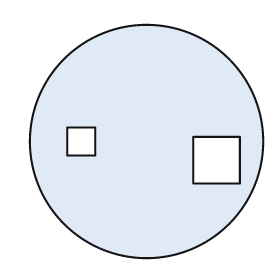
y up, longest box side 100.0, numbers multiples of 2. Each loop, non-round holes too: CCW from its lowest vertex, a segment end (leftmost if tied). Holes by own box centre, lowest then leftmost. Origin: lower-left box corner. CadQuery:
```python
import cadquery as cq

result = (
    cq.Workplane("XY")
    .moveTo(50.0, 50.0)
    .circle(50.0)
    .moveTo(70.0, 32.0)
    .lineTo(90.0, 32.0)
    .lineTo(90.0, 52.0)
    .lineTo(70.0, 52.0)
    .close()
    .moveTo(16.0, 44.0)
    .lineTo(28.0, 44.0)
    .lineTo(28.0, 56.0)
    .lineTo(16.0, 56.0)
    .close()
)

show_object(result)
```